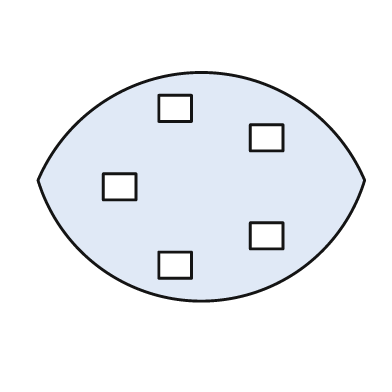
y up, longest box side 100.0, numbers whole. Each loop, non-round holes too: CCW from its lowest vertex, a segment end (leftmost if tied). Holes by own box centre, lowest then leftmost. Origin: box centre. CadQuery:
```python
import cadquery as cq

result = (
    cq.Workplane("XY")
    .moveTo(-50.0, 2.0)
    .threePointArc((0.0, -35.0), (50.0, 2.0))
    .threePointArc((0.0, 35.0), (-50.0, 2.0))
    .close()
    .moveTo(-13.0, -28.0)
    .lineTo(-3.0, -28.0)
    .lineTo(-3.0, -20.0)
    .lineTo(-13.0, -20.0)
    .close()
    .moveTo(15.0, -19.0)
    .lineTo(25.0, -19.0)
    .lineTo(25.0, -11.0)
    .lineTo(15.0, -11.0)
    .close()
    .moveTo(-30.0, -4.0)
    .lineTo(-20.0, -4.0)
    .lineTo(-20.0, 4.0)
    .lineTo(-30.0, 4.0)
    .close()
    .moveTo(15.0, 11.0)
    .lineTo(25.0, 11.0)
    .lineTo(25.0, 19.0)
    .lineTo(15.0, 19.0)
    .close()
    .moveTo(-13.0, 20.0)
    .lineTo(-3.0, 20.0)
    .lineTo(-3.0, 28.0)
    .lineTo(-13.0, 28.0)
    .close()
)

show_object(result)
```